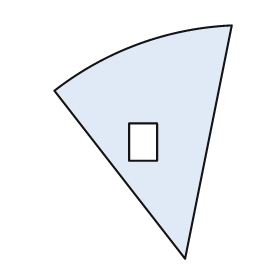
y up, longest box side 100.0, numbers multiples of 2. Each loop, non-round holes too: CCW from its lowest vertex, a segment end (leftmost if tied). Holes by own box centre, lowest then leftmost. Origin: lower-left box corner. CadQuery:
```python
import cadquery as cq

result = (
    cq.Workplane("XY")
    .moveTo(56.0, 0.0)
    .lineTo(76.0, 100.0)
    .threePointArc((36.0, 92.0), (0.0, 72.0))
    .close()
    .moveTo(32.0, 42.0)
    .lineTo(44.0, 42.0)
    .lineTo(44.0, 58.0)
    .lineTo(32.0, 58.0)
    .close()
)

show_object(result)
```